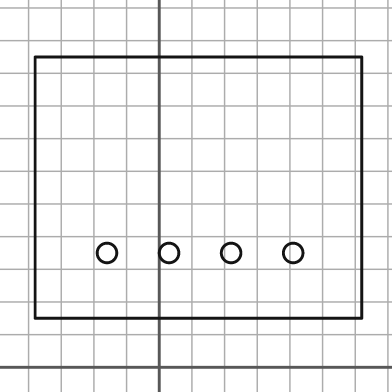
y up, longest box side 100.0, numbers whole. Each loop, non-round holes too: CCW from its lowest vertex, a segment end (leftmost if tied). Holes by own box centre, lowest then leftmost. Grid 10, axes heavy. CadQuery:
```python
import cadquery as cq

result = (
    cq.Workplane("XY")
    .moveTo(-38.0, 15.0)
    .lineTo(62.0, 15.0)
    .lineTo(62.0, 95.0)
    .lineTo(-38.0, 95.0)
    .close()
    .moveTo(-16.0, 35.0)
    .circle(3.0)
    .moveTo(3.0, 35.0)
    .circle(3.0)
    .moveTo(22.0, 35.0)
    .circle(3.0)
    .moveTo(41.0, 35.0)
    .circle(3.0)
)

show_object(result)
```